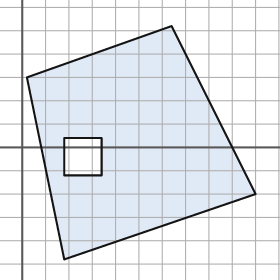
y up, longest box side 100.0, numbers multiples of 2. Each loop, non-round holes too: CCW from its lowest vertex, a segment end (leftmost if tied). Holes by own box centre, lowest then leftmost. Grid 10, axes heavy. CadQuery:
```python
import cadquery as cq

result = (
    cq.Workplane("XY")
    .moveTo(18.0, -48.0)
    .lineTo(100.0, -20.0)
    .lineTo(64.0, 52.0)
    .lineTo(2.0, 30.0)
    .close()
    .moveTo(18.0, -12.0)
    .lineTo(34.0, -12.0)
    .lineTo(34.0, 4.0)
    .lineTo(18.0, 4.0)
    .close()
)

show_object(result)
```